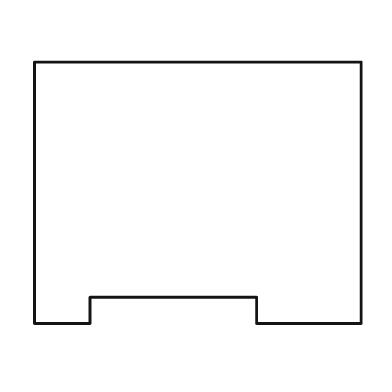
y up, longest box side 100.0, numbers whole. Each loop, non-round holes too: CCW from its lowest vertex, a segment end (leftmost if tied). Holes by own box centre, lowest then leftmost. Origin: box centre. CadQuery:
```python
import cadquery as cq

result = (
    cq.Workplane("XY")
    .moveTo(-50.0, -40.0)
    .lineTo(-33.0, -40.0)
    .lineTo(-33.0, -32.0)
    .lineTo(18.0, -32.0)
    .lineTo(18.0, -40.0)
    .lineTo(50.0, -40.0)
    .lineTo(50.0, 40.0)
    .lineTo(-50.0, 40.0)
    .close()
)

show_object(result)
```